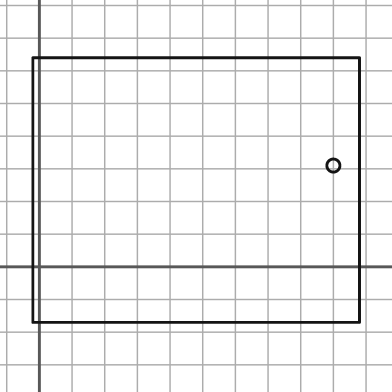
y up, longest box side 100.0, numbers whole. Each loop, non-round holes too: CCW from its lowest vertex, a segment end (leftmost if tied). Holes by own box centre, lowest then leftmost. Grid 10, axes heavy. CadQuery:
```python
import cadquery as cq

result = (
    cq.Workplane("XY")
    .moveTo(-2.0, -17.0)
    .lineTo(98.0, -17.0)
    .lineTo(98.0, 64.0)
    .lineTo(-2.0, 64.0)
    .close()
    .moveTo(90.0, 31.0)
    .circle(2.0)
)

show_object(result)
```